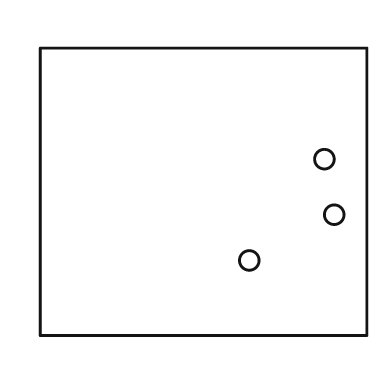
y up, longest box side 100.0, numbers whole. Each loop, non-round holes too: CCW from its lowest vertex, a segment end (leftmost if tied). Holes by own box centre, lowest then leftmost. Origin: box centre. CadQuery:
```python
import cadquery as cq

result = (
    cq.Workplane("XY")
    .moveTo(-50.0, -44.0)
    .lineTo(50.0, -44.0)
    .lineTo(50.0, 44.0)
    .lineTo(-50.0, 44.0)
    .close()
    .moveTo(14.0, -21.0)
    .circle(3.0)
    .moveTo(40.0, -7.0)
    .circle(3.0)
    .moveTo(37.0, 10.0)
    .circle(3.0)
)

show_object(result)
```